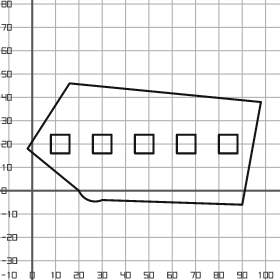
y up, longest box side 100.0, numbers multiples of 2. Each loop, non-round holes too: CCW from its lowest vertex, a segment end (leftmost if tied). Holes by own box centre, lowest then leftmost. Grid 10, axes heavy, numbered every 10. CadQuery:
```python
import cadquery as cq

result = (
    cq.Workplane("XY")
    .moveTo(90.0, -6.0)
    .lineTo(98.0, 38.0)
    .lineTo(16.0, 46.0)
    .lineTo(-2.0, 18.0)
    .lineTo(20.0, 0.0)
    .threePointArc((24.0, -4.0), (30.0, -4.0))
    .close()
    .moveTo(8.0, 16.0)
    .lineTo(16.0, 16.0)
    .lineTo(16.0, 24.0)
    .lineTo(8.0, 24.0)
    .close()
    .moveTo(26.0, 16.0)
    .lineTo(34.0, 16.0)
    .lineTo(34.0, 24.0)
    .lineTo(26.0, 24.0)
    .close()
    .moveTo(44.0, 16.0)
    .lineTo(52.0, 16.0)
    .lineTo(52.0, 24.0)
    .lineTo(44.0, 24.0)
    .close()
    .moveTo(62.0, 16.0)
    .lineTo(70.0, 16.0)
    .lineTo(70.0, 24.0)
    .lineTo(62.0, 24.0)
    .close()
    .moveTo(80.0, 16.0)
    .lineTo(88.0, 16.0)
    .lineTo(88.0, 24.0)
    .lineTo(80.0, 24.0)
    .close()
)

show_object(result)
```